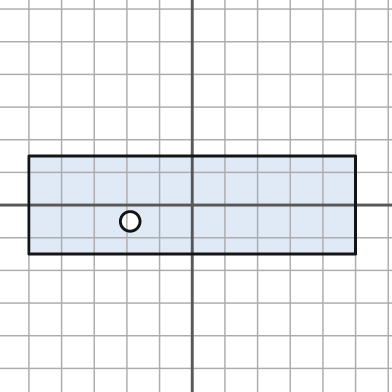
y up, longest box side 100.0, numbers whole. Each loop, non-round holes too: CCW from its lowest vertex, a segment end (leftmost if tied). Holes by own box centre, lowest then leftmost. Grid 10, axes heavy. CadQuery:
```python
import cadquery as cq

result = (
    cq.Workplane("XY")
    .moveTo(-50.0, -15.0)
    .lineTo(50.0, -15.0)
    .lineTo(50.0, 15.0)
    .lineTo(-50.0, 15.0)
    .close()
    .moveTo(-19.0, -5.0)
    .circle(3.0)
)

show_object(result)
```